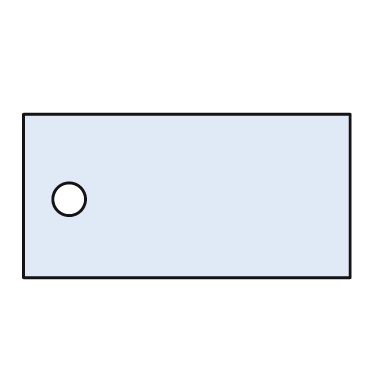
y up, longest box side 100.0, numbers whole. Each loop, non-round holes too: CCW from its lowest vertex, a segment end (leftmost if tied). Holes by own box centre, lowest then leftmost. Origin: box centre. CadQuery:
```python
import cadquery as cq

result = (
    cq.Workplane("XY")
    .moveTo(-50.0, -25.0)
    .lineTo(50.0, -25.0)
    .lineTo(50.0, 25.0)
    .lineTo(-50.0, 25.0)
    .close()
    .moveTo(-36.0, -1.0)
    .circle(5.0)
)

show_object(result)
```